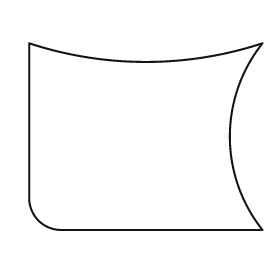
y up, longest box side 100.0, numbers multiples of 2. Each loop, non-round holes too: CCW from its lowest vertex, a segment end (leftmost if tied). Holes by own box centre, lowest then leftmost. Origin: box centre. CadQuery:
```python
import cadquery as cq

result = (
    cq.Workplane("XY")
    .moveTo(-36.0, -40.0)
    .lineTo(50.0, -40.0)
    .threePointArc((36.0, 0.0), (50.0, 40.0))
    .threePointArc((0.0, 32.0), (-50.0, 40.0))
    .lineTo(-50.0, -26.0)
    .threePointArc((-46.0, -36.0), (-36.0, -40.0))
    .close()
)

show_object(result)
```